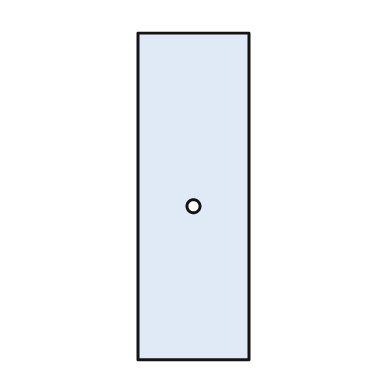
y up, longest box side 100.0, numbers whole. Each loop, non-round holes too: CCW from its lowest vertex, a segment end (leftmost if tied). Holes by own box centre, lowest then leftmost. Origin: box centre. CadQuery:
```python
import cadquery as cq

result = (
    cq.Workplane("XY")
    .moveTo(-17.0, -50.0)
    .lineTo(17.0, -50.0)
    .lineTo(17.0, 50.0)
    .lineTo(-17.0, 50.0)
    .close()
    .moveTo(0.0, -3.0)
    .circle(2.0)
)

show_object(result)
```